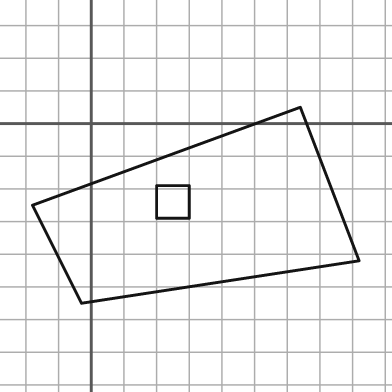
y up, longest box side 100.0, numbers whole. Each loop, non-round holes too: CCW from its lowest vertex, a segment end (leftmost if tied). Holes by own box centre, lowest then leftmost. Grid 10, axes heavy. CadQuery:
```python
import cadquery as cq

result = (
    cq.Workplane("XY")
    .moveTo(-3.0, -55.0)
    .lineTo(82.0, -42.0)
    .lineTo(64.0, 5.0)
    .lineTo(-18.0, -25.0)
    .close()
    .moveTo(20.0, -29.0)
    .lineTo(30.0, -29.0)
    .lineTo(30.0, -19.0)
    .lineTo(20.0, -19.0)
    .close()
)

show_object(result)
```